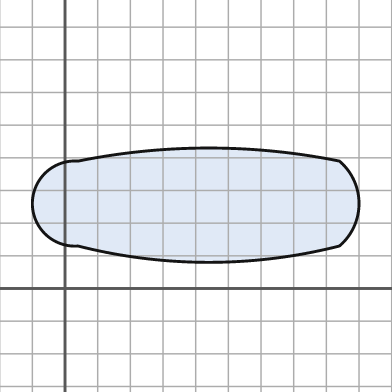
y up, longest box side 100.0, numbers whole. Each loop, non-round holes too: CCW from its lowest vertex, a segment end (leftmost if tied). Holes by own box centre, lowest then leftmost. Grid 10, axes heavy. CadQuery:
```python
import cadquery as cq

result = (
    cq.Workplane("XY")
    .moveTo(4.0, 13.0)
    .threePointArc((44.0, 8.0), (84.0, 13.0))
    .threePointArc((90.0, 26.0), (84.0, 39.0))
    .threePointArc((44.0, 43.0), (4.0, 39.0))
    .threePointArc((-10.0, 26.0), (4.0, 13.0))
    .close()
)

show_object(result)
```